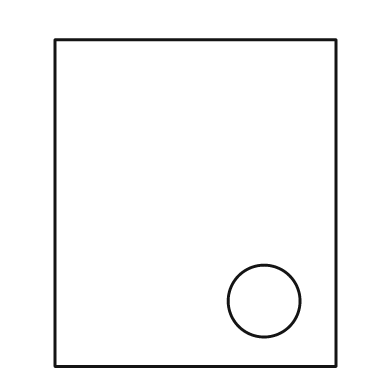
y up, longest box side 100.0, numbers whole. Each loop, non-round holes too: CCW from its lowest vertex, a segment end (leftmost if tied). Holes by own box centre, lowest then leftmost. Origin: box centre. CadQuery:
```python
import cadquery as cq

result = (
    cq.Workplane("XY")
    .moveTo(-43.0, -50.0)
    .lineTo(43.0, -50.0)
    .lineTo(43.0, 50.0)
    .lineTo(-43.0, 50.0)
    .close()
    .moveTo(21.0, -30.0)
    .circle(11.0)
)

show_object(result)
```